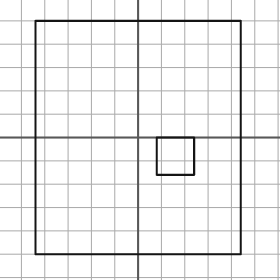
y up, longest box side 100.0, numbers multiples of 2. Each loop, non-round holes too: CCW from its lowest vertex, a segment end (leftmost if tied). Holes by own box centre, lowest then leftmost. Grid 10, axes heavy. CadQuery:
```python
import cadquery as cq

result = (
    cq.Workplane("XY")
    .moveTo(-44.0, -50.0)
    .lineTo(44.0, -50.0)
    .lineTo(44.0, 50.0)
    .lineTo(-44.0, 50.0)
    .close()
    .moveTo(8.0, -16.0)
    .lineTo(24.0, -16.0)
    .lineTo(24.0, 0.0)
    .lineTo(8.0, 0.0)
    .close()
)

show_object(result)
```